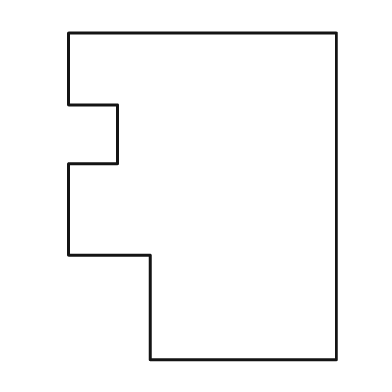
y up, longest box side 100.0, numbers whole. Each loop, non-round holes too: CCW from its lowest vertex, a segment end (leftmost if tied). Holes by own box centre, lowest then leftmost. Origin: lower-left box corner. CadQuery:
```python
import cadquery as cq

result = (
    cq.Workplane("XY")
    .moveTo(25.0, 0.0)
    .lineTo(82.0, 0.0)
    .lineTo(82.0, 100.0)
    .lineTo(0.0, 100.0)
    .lineTo(0.0, 78.0)
    .lineTo(15.0, 78.0)
    .lineTo(15.0, 60.0)
    .lineTo(0.0, 60.0)
    .lineTo(0.0, 32.0)
    .lineTo(25.0, 32.0)
    .close()
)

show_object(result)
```